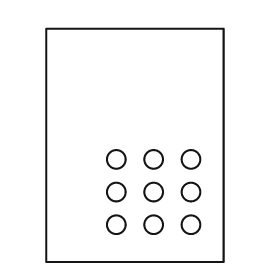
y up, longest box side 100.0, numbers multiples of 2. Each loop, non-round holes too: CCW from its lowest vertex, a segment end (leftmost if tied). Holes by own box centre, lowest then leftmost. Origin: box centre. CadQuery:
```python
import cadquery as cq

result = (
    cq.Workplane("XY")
    .moveTo(-38.0, -50.0)
    .lineTo(38.0, -50.0)
    .lineTo(38.0, 50.0)
    .lineTo(-38.0, 50.0)
    .close()
    .moveTo(-8.0, -34.0)
    .circle(4.0)
    .moveTo(8.0, -34.0)
    .circle(4.0)
    .moveTo(24.0, -34.0)
    .circle(4.0)
    .moveTo(-8.0, -20.0)
    .circle(4.0)
    .moveTo(8.0, -20.0)
    .circle(4.0)
    .moveTo(24.0, -20.0)
    .circle(4.0)
    .moveTo(-8.0, -6.0)
    .circle(4.0)
    .moveTo(8.0, -6.0)
    .circle(4.0)
    .moveTo(24.0, -6.0)
    .circle(4.0)
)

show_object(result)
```